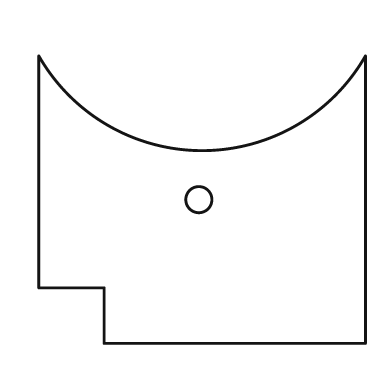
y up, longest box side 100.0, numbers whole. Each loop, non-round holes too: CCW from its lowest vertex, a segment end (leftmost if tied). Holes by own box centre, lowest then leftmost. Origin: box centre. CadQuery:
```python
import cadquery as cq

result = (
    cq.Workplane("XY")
    .moveTo(-30.0, -44.0)
    .lineTo(50.0, -44.0)
    .lineTo(50.0, 44.0)
    .threePointArc((0.0, 15.0), (-50.0, 44.0))
    .lineTo(-50.0, -27.0)
    .lineTo(-30.0, -27.0)
    .close()
    .moveTo(-1.0, 0.0)
    .circle(4.0)
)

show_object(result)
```